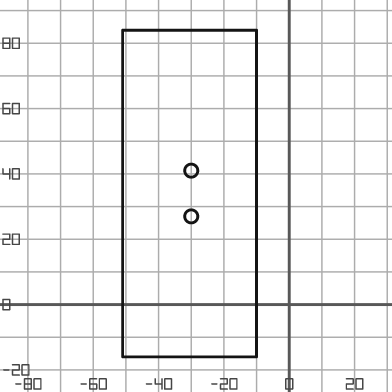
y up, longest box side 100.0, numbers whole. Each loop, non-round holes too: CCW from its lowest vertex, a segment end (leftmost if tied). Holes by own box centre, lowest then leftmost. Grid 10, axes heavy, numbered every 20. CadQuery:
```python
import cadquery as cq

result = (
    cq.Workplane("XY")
    .moveTo(-51.0, -16.0)
    .lineTo(-10.0, -16.0)
    .lineTo(-10.0, 84.0)
    .lineTo(-51.0, 84.0)
    .close()
    .moveTo(-30.0, 27.0)
    .circle(2.0)
    .moveTo(-30.0, 41.0)
    .circle(2.0)
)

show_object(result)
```